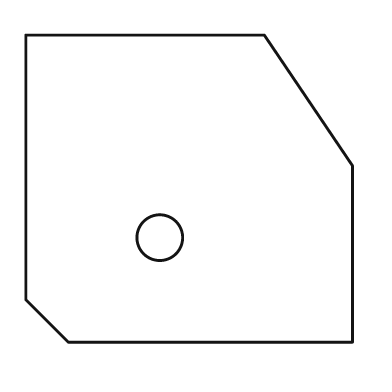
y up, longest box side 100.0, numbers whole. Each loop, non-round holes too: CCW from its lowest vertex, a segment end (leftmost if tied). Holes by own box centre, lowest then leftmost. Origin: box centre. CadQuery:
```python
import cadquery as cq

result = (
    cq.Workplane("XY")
    .moveTo(-37.0, -47.0)
    .lineTo(50.0, -47.0)
    .lineTo(50.0, 7.0)
    .lineTo(23.0, 47.0)
    .lineTo(-50.0, 47.0)
    .lineTo(-50.0, -34.0)
    .close()
    .moveTo(-9.0, -15.0)
    .circle(7.0)
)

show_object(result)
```